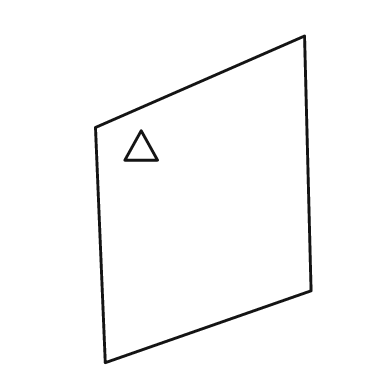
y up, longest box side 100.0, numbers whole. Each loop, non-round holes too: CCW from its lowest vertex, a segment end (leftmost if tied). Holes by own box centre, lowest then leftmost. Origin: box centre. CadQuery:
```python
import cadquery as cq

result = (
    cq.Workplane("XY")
    .moveTo(-30.0, -50.0)
    .lineTo(33.0, -28.0)
    .lineTo(31.0, 50.0)
    .lineTo(-33.0, 22.0)
    .close()
    .moveTo(-24.0, 12.0)
    .lineTo(-14.0, 12.0)
    .lineTo(-19.0, 21.0)
    .close()
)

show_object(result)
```